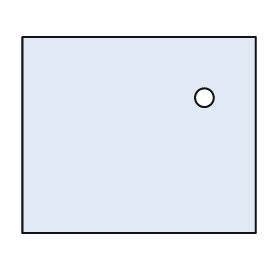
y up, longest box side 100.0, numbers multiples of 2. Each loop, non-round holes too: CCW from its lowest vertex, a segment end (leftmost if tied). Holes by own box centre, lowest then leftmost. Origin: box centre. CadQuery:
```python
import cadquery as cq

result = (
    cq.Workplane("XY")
    .moveTo(-50.0, -42.0)
    .lineTo(50.0, -42.0)
    .lineTo(50.0, 42.0)
    .lineTo(-50.0, 42.0)
    .close()
    .moveTo(28.0, 16.0)
    .circle(4.0)
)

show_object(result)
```